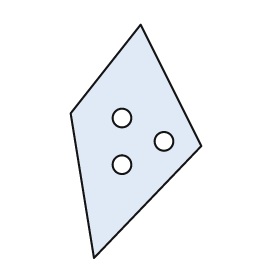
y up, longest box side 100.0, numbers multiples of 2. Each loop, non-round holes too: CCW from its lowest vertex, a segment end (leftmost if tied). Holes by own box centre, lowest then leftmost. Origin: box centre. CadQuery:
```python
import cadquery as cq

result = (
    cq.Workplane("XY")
    .moveTo(-18.0, -50.0)
    .lineTo(28.0, -2.0)
    .lineTo(2.0, 50.0)
    .lineTo(-28.0, 12.0)
    .close()
    .moveTo(-6.0, -10.0)
    .circle(4.0)
    .moveTo(12.0, 0.0)
    .circle(4.0)
    .moveTo(-6.0, 10.0)
    .circle(4.0)
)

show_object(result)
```